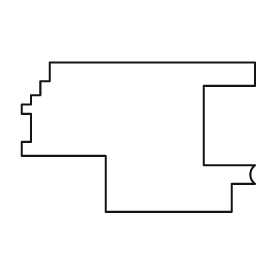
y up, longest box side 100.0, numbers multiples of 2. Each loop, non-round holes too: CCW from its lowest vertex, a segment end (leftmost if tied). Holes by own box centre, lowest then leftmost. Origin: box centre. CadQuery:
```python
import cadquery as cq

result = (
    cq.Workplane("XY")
    .moveTo(-14.0, -32.0)
    .lineTo(40.0, -32.0)
    .lineTo(40.0, -20.0)
    .lineTo(50.0, -20.0)
    .threePointArc((48.0, -16.0), (50.0, -12.0))
    .lineTo(28.0, -12.0)
    .lineTo(28.0, 22.0)
    .lineTo(50.0, 22.0)
    .lineTo(50.0, 32.0)
    .lineTo(-38.0, 32.0)
    .lineTo(-38.0, 24.0)
    .lineTo(-42.0, 24.0)
    .lineTo(-42.0, 18.0)
    .lineTo(-46.0, 18.0)
    .lineTo(-46.0, 14.0)
    .lineTo(-50.0, 14.0)
    .lineTo(-50.0, 10.0)
    .lineTo(-46.0, 10.0)
    .lineTo(-46.0, -2.0)
    .lineTo(-50.0, -2.0)
    .lineTo(-50.0, -8.0)
    .lineTo(-14.0, -8.0)
    .close()
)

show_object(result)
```